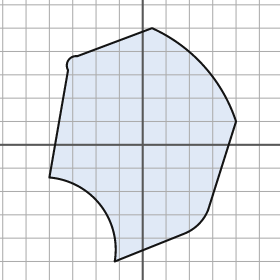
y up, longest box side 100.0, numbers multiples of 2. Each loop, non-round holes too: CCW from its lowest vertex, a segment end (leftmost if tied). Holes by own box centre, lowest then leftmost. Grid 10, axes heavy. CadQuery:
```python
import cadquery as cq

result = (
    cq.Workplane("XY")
    .moveTo(-12.0, -50.0)
    .lineTo(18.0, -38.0)
    .threePointArc((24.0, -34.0), (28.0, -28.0))
    .lineTo(40.0, 10.0)
    .threePointArc((26.0, 34.0), (4.0, 50.0))
    .lineTo(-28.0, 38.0)
    .threePointArc((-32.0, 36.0), (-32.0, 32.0))
    .lineTo(-40.0, -14.0)
    .threePointArc((-18.0, -26.0), (-12.0, -50.0))
    .close()
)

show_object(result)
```